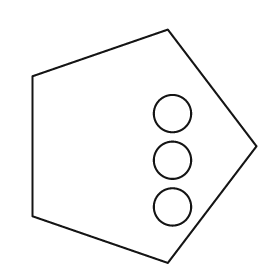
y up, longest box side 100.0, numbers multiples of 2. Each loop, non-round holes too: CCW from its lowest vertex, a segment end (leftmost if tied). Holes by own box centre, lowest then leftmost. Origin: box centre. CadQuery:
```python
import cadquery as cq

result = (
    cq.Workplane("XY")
    .moveTo(10.0, -50.0)
    .lineTo(48.0, 0.0)
    .lineTo(10.0, 50.0)
    .lineTo(-48.0, 30.0)
    .lineTo(-48.0, -30.0)
    .close()
    .moveTo(12.0, -26.0)
    .circle(8.0)
    .moveTo(12.0, -6.0)
    .circle(8.0)
    .moveTo(12.0, 14.0)
    .circle(8.0)
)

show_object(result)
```